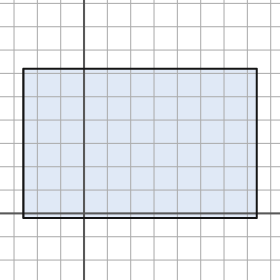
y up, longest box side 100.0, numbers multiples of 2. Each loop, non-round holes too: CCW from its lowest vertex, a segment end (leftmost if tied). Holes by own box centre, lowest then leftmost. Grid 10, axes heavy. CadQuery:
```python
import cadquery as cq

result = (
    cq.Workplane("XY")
    .moveTo(-26.0, -2.0)
    .lineTo(74.0, -2.0)
    .lineTo(74.0, 62.0)
    .lineTo(-26.0, 62.0)
    .close()
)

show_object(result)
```